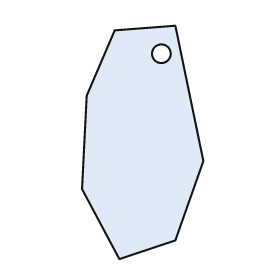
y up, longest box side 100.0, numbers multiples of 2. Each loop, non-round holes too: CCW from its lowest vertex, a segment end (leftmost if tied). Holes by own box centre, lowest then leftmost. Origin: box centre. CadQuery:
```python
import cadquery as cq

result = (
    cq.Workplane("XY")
    .moveTo(-10.0, -50.0)
    .lineTo(14.0, -42.0)
    .lineTo(26.0, -8.0)
    .lineTo(14.0, 50.0)
    .lineTo(-12.0, 48.0)
    .lineTo(-24.0, 20.0)
    .lineTo(-26.0, -20.0)
    .close()
    .moveTo(8.0, 38.0)
    .circle(4.0)
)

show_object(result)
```